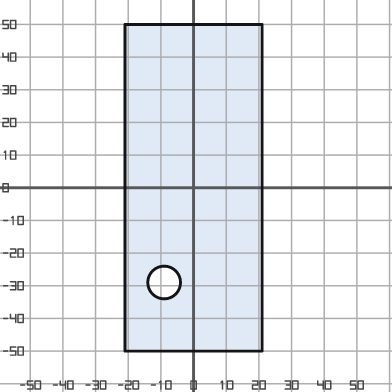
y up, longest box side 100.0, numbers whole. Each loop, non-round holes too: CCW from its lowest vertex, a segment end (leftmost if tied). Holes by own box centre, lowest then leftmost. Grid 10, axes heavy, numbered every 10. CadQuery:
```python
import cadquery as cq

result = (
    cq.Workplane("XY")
    .moveTo(-21.0, -50.0)
    .lineTo(21.0, -50.0)
    .lineTo(21.0, 50.0)
    .lineTo(-21.0, 50.0)
    .close()
    .moveTo(-9.0, -29.0)
    .circle(5.0)
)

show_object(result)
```